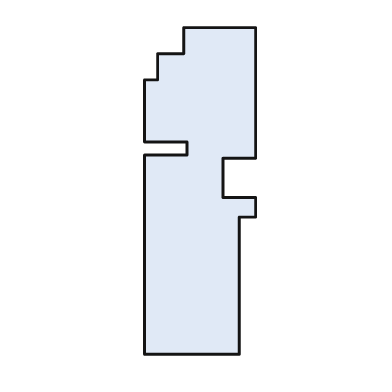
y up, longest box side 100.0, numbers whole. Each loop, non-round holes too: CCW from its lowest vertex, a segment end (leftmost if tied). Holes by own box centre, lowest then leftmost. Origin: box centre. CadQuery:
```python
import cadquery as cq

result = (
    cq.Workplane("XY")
    .moveTo(-17.0, -50.0)
    .lineTo(12.0, -50.0)
    .lineTo(12.0, -8.0)
    .lineTo(17.0, -8.0)
    .lineTo(17.0, -2.0)
    .lineTo(7.0, -2.0)
    .lineTo(7.0, 10.0)
    .lineTo(17.0, 10.0)
    .lineTo(17.0, 50.0)
    .lineTo(-5.0, 50.0)
    .lineTo(-5.0, 42.0)
    .lineTo(-13.0, 42.0)
    .lineTo(-13.0, 34.0)
    .lineTo(-17.0, 34.0)
    .lineTo(-17.0, 15.0)
    .lineTo(-4.0, 15.0)
    .lineTo(-4.0, 11.0)
    .lineTo(-17.0, 11.0)
    .close()
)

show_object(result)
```